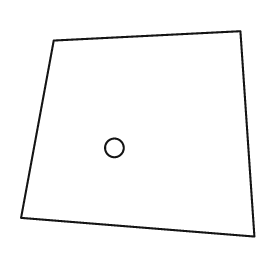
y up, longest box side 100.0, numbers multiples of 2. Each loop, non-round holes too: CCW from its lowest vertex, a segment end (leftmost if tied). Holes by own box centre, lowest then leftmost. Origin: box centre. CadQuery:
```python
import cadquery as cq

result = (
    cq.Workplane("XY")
    .moveTo(50.0, -44.0)
    .lineTo(44.0, 44.0)
    .lineTo(-36.0, 40.0)
    .lineTo(-50.0, -36.0)
    .close()
    .moveTo(-10.0, -6.0)
    .circle(4.0)
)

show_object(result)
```